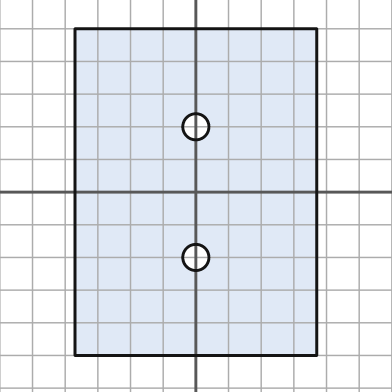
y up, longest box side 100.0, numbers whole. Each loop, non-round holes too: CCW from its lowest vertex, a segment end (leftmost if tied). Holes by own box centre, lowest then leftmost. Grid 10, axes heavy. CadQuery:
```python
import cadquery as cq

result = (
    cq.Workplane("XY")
    .moveTo(-37.0, -50.0)
    .lineTo(37.0, -50.0)
    .lineTo(37.0, 50.0)
    .lineTo(-37.0, 50.0)
    .close()
    .moveTo(0.0, -20.0)
    .circle(4.0)
    .moveTo(0.0, 20.0)
    .circle(4.0)
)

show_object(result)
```